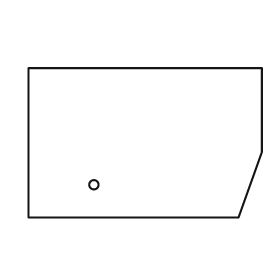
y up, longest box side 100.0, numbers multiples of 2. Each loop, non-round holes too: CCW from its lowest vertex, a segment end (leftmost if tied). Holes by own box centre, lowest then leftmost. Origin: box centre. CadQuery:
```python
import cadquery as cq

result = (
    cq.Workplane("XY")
    .moveTo(-50.0, -32.0)
    .lineTo(40.0, -32.0)
    .lineTo(50.0, -4.0)
    .lineTo(50.0, 32.0)
    .lineTo(-50.0, 32.0)
    .close()
    .moveTo(-22.0, -18.0)
    .circle(2.0)
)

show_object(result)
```